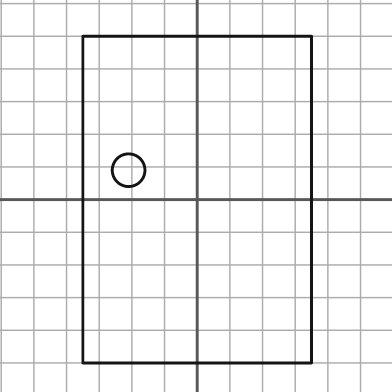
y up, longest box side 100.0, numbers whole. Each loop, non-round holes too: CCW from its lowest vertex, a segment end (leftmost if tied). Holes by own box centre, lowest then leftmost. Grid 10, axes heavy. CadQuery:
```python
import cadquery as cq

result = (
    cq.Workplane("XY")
    .moveTo(-35.0, -50.0)
    .lineTo(35.0, -50.0)
    .lineTo(35.0, 50.0)
    .lineTo(-35.0, 50.0)
    .close()
    .moveTo(-21.0, 9.0)
    .circle(5.0)
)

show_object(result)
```